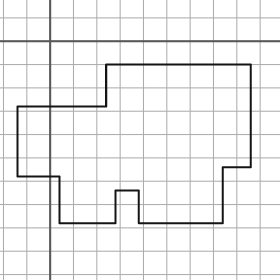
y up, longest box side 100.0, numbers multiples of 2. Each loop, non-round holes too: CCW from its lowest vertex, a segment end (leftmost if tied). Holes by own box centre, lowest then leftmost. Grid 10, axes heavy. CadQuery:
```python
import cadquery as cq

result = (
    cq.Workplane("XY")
    .moveTo(4.0, -78.0)
    .lineTo(28.0, -78.0)
    .lineTo(28.0, -64.0)
    .lineTo(38.0, -64.0)
    .lineTo(38.0, -78.0)
    .lineTo(74.0, -78.0)
    .lineTo(74.0, -54.0)
    .lineTo(86.0, -54.0)
    .lineTo(86.0, -10.0)
    .lineTo(24.0, -10.0)
    .lineTo(24.0, -28.0)
    .lineTo(-14.0, -28.0)
    .lineTo(-14.0, -58.0)
    .lineTo(4.0, -58.0)
    .close()
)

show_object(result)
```